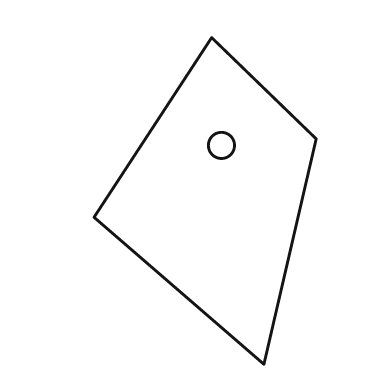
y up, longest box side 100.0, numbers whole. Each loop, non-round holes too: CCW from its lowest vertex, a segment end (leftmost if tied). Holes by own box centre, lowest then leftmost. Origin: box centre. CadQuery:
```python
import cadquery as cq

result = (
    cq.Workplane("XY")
    .moveTo(18.0, -50.0)
    .lineTo(34.0, 19.0)
    .lineTo(2.0, 50.0)
    .lineTo(-34.0, -5.0)
    .close()
    .moveTo(5.0, 17.0)
    .circle(4.0)
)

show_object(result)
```